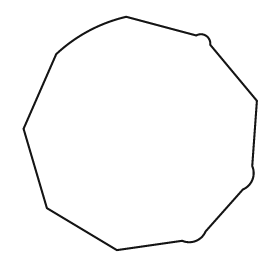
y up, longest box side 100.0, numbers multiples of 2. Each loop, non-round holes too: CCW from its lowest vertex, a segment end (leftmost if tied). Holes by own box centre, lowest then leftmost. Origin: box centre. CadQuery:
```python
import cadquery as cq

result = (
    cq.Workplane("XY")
    .moveTo(-10.0, -50.0)
    .lineTo(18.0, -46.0)
    .threePointArc((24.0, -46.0), (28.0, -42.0))
    .lineTo(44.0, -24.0)
    .threePointArc((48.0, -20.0), (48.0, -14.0))
    .lineTo(50.0, 14.0)
    .lineTo(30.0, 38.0)
    .threePointArc((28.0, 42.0), (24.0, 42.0))
    .lineTo(-6.0, 50.0)
    .threePointArc((-22.0, 44.0), (-36.0, 34.0))
    .lineTo(-50.0, 2.0)
    .lineTo(-40.0, -32.0)
    .close()
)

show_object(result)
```